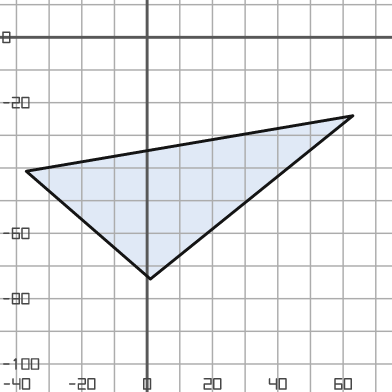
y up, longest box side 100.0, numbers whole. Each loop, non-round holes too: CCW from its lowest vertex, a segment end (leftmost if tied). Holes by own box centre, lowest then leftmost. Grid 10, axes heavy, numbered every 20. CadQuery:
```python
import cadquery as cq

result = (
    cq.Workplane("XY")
    .moveTo(1.0, -74.0)
    .lineTo(63.0, -24.0)
    .lineTo(-37.0, -41.0)
    .close()
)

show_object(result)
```